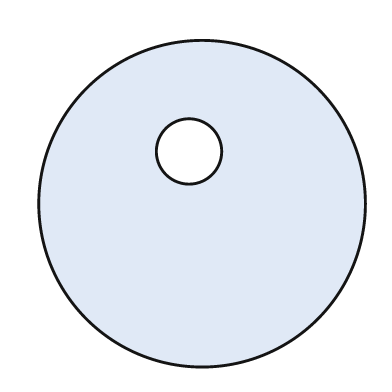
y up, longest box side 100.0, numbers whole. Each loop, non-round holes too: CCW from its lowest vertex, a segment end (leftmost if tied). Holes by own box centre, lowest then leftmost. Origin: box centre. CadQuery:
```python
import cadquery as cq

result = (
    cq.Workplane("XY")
    .moveTo(0.0, 0.0)
    .circle(50.0)
    .moveTo(-4.0, 16.0)
    .circle(10.0)
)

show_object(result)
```